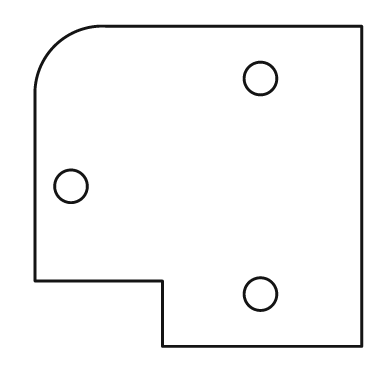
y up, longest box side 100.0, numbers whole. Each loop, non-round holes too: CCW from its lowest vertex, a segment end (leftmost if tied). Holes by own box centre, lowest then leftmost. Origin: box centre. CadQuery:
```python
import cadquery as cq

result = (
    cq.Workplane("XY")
    .moveTo(-11.0, -49.0)
    .lineTo(50.0, -49.0)
    .lineTo(50.0, 49.0)
    .lineTo(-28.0, 49.0)
    .threePointArc((-44.0, 43.0), (-50.0, 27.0))
    .lineTo(-50.0, -29.0)
    .lineTo(-11.0, -29.0)
    .close()
    .moveTo(19.0, -33.0)
    .circle(5.0)
    .moveTo(-39.0, 0.0)
    .circle(5.0)
    .moveTo(19.0, 33.0)
    .circle(5.0)
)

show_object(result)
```